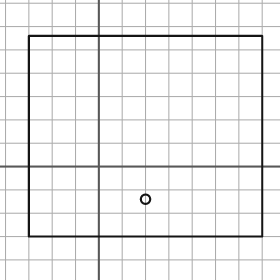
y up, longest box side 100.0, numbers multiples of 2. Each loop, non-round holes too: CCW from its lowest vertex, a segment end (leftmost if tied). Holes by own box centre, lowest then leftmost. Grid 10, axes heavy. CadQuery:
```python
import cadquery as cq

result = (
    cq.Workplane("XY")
    .moveTo(-30.0, -30.0)
    .lineTo(70.0, -30.0)
    .lineTo(70.0, 56.0)
    .lineTo(-30.0, 56.0)
    .close()
    .moveTo(20.0, -14.0)
    .circle(2.0)
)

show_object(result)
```